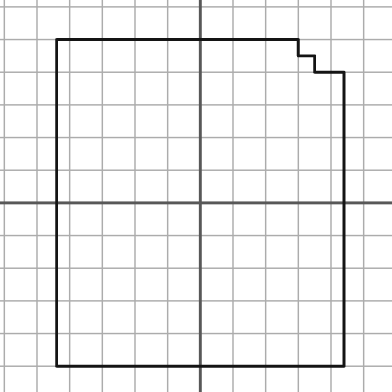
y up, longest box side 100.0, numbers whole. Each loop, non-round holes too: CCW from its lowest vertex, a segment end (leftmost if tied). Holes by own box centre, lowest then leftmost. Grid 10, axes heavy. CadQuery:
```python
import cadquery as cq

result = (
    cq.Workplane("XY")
    .moveTo(-44.0, -50.0)
    .lineTo(44.0, -50.0)
    .lineTo(44.0, 40.0)
    .lineTo(35.0, 40.0)
    .lineTo(35.0, 45.0)
    .lineTo(30.0, 45.0)
    .lineTo(30.0, 50.0)
    .lineTo(-44.0, 50.0)
    .close()
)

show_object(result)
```